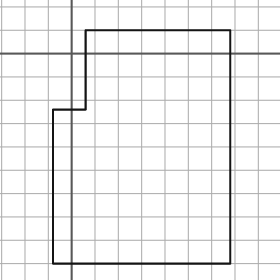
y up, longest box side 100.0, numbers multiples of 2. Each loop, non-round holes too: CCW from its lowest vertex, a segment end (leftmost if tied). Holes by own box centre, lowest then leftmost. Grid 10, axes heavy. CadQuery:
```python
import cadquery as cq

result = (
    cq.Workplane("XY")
    .moveTo(-8.0, -90.0)
    .lineTo(68.0, -90.0)
    .lineTo(68.0, 10.0)
    .lineTo(6.0, 10.0)
    .lineTo(6.0, -24.0)
    .lineTo(-8.0, -24.0)
    .close()
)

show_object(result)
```